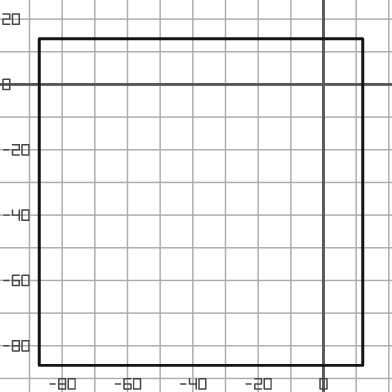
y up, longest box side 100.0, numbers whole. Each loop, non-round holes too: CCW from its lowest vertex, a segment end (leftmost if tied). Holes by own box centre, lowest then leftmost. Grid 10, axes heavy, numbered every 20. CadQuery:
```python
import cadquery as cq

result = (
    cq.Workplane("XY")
    .moveTo(-87.0, -86.0)
    .lineTo(12.0, -86.0)
    .lineTo(12.0, 14.0)
    .lineTo(-87.0, 14.0)
    .close()
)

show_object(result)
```